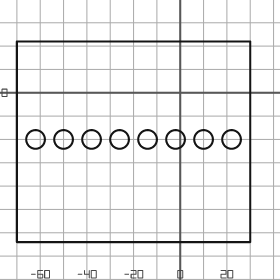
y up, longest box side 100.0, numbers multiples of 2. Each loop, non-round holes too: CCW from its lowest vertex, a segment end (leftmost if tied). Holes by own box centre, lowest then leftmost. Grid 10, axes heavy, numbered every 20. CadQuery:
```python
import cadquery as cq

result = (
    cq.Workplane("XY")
    .moveTo(-70.0, -64.0)
    .lineTo(30.0, -64.0)
    .lineTo(30.0, 22.0)
    .lineTo(-70.0, 22.0)
    .close()
    .moveTo(-62.0, -20.0)
    .circle(4.0)
    .moveTo(-50.0, -20.0)
    .circle(4.0)
    .moveTo(-38.0, -20.0)
    .circle(4.0)
    .moveTo(-26.0, -20.0)
    .circle(4.0)
    .moveTo(-14.0, -20.0)
    .circle(4.0)
    .moveTo(-2.0, -20.0)
    .circle(4.0)
    .moveTo(10.0, -20.0)
    .circle(4.0)
    .moveTo(22.0, -20.0)
    .circle(4.0)
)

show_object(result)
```